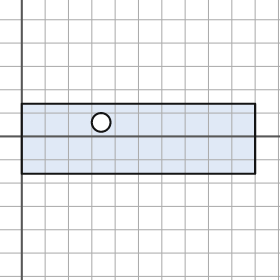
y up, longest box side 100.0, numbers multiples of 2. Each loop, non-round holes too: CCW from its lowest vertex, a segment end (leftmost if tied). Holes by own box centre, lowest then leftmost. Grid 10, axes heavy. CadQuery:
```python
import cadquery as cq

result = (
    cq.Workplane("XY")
    .moveTo(0.0, -16.0)
    .lineTo(100.0, -16.0)
    .lineTo(100.0, 14.0)
    .lineTo(0.0, 14.0)
    .close()
    .moveTo(34.0, 6.0)
    .circle(4.0)
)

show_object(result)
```